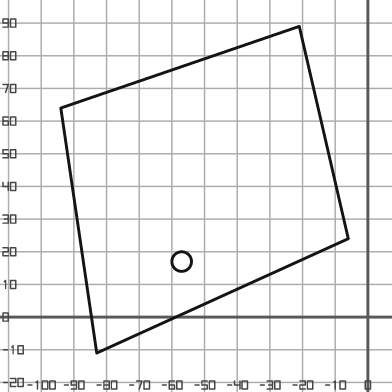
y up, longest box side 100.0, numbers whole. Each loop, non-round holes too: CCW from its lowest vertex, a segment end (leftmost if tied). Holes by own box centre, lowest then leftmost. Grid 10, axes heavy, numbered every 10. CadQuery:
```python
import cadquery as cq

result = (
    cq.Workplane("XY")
    .moveTo(-83.0, -11.0)
    .lineTo(-6.0, 24.0)
    .lineTo(-21.0, 89.0)
    .lineTo(-94.0, 64.0)
    .close()
    .moveTo(-57.0, 17.0)
    .circle(3.0)
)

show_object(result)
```